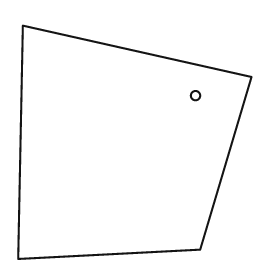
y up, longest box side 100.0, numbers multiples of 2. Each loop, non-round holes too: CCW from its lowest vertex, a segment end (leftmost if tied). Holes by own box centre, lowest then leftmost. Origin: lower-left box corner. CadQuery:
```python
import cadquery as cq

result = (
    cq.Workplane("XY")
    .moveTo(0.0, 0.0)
    .lineTo(78.0, 4.0)
    .lineTo(100.0, 78.0)
    .lineTo(2.0, 100.0)
    .close()
    .moveTo(76.0, 70.0)
    .circle(2.0)
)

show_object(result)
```